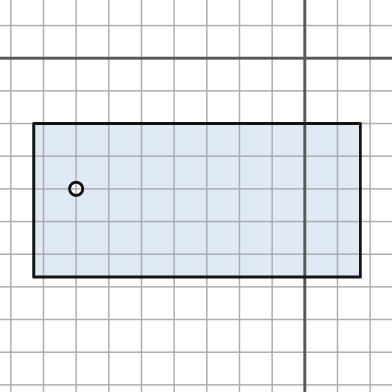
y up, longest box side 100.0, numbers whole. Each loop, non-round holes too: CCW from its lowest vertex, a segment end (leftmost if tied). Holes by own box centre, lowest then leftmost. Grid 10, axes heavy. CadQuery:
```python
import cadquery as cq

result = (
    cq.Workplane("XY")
    .moveTo(-83.0, -67.0)
    .lineTo(17.0, -67.0)
    .lineTo(17.0, -20.0)
    .lineTo(-83.0, -20.0)
    .close()
    .moveTo(-70.0, -40.0)
    .circle(2.0)
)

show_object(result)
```